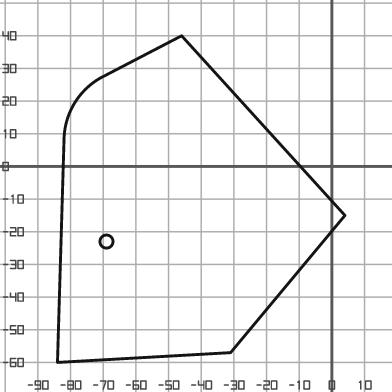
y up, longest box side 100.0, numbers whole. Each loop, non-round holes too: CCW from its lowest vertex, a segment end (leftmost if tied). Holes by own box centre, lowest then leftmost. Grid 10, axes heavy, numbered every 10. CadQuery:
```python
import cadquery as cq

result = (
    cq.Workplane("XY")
    .moveTo(-84.0, -60.0)
    .lineTo(-31.0, -57.0)
    .lineTo(4.0, -15.0)
    .lineTo(-46.0, 40.0)
    .lineTo(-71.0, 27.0)
    .threePointArc((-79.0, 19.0), (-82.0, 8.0))
    .close()
    .moveTo(-69.0, -23.0)
    .circle(2.0)
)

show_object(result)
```